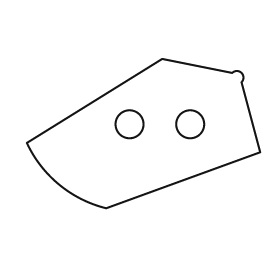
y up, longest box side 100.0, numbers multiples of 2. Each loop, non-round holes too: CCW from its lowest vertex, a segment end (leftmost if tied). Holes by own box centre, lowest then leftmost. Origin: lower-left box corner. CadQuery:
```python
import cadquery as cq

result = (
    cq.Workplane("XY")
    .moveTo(34.0, 0.0)
    .lineTo(100.0, 24.0)
    .lineTo(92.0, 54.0)
    .threePointArc((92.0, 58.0), (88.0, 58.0))
    .lineTo(58.0, 64.0)
    .lineTo(0.0, 28.0)
    .threePointArc((14.0, 10.0), (34.0, 0.0))
    .close()
    .moveTo(44.0, 36.0)
    .circle(6.0)
    .moveTo(70.0, 36.0)
    .circle(6.0)
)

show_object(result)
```